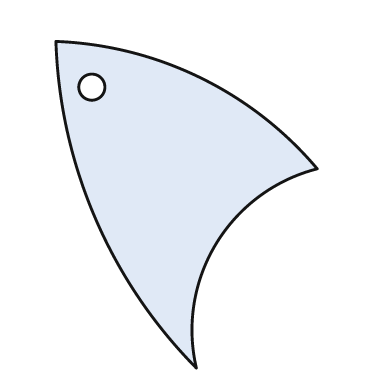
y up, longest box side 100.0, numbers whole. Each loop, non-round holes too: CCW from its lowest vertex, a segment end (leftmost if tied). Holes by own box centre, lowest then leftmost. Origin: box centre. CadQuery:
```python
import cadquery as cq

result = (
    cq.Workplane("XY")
    .moveTo(3.0, -50.0)
    .threePointArc((9.0, -12.0), (40.0, 11.0))
    .threePointArc((4.0, 39.0), (-40.0, 50.0))
    .threePointArc((-28.0, -4.0), (3.0, -50.0))
    .close()
    .moveTo(-29.0, 36.0)
    .circle(4.0)
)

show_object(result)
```